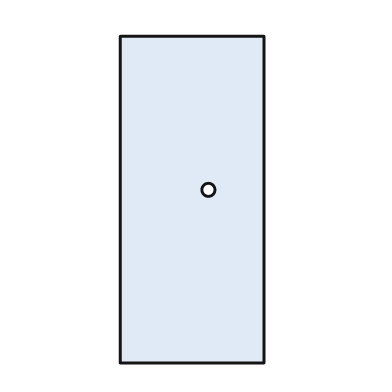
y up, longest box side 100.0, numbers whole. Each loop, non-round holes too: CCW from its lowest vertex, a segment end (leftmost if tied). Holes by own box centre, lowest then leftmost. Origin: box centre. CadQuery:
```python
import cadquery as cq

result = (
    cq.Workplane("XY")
    .moveTo(-22.0, -50.0)
    .lineTo(22.0, -50.0)
    .lineTo(22.0, 50.0)
    .lineTo(-22.0, 50.0)
    .close()
    .moveTo(5.0, 3.0)
    .circle(2.0)
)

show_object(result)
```